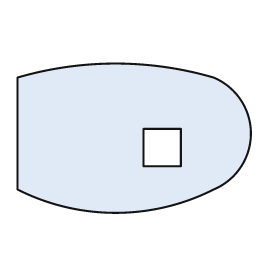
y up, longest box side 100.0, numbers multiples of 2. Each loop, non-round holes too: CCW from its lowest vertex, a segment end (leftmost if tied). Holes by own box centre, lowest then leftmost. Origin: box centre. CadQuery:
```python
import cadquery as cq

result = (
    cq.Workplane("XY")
    .moveTo(-50.0, -22.0)
    .threePointArc((-8.0, -32.0), (34.0, -22.0))
    .threePointArc((50.0, 2.0), (34.0, 26.0))
    .threePointArc((-8.0, 32.0), (-50.0, 26.0))
    .close()
    .moveTo(4.0, -12.0)
    .lineTo(20.0, -12.0)
    .lineTo(20.0, 4.0)
    .lineTo(4.0, 4.0)
    .close()
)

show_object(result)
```